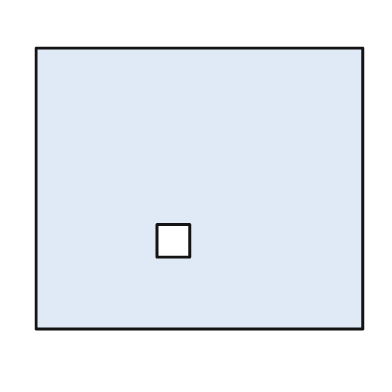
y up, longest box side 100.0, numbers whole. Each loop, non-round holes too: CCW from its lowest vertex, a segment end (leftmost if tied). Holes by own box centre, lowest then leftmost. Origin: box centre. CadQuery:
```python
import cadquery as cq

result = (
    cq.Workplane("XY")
    .moveTo(-50.0, -43.0)
    .lineTo(50.0, -43.0)
    .lineTo(50.0, 43.0)
    .lineTo(-50.0, 43.0)
    .close()
    .moveTo(-13.0, -21.0)
    .lineTo(-3.0, -21.0)
    .lineTo(-3.0, -11.0)
    .lineTo(-13.0, -11.0)
    .close()
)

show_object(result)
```